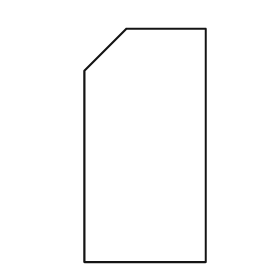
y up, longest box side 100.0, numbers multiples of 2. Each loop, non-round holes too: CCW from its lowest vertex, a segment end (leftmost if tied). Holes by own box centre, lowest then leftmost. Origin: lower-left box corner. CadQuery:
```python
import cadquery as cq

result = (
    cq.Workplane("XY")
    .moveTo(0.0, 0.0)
    .lineTo(52.0, 0.0)
    .lineTo(52.0, 100.0)
    .lineTo(18.0, 100.0)
    .lineTo(0.0, 82.0)
    .close()
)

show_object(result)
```